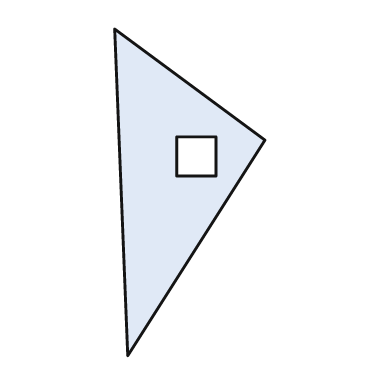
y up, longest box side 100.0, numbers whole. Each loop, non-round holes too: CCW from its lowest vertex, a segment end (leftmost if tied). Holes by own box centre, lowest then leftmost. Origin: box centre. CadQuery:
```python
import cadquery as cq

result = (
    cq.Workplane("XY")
    .moveTo(-19.0, -50.0)
    .lineTo(23.0, 16.0)
    .lineTo(-23.0, 50.0)
    .close()
    .moveTo(-4.0, 5.0)
    .lineTo(8.0, 5.0)
    .lineTo(8.0, 17.0)
    .lineTo(-4.0, 17.0)
    .close()
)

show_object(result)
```